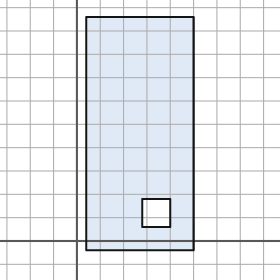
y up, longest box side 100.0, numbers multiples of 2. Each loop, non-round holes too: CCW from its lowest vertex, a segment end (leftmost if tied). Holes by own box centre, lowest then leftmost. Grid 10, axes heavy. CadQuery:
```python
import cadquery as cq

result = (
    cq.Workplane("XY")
    .moveTo(4.0, -4.0)
    .lineTo(50.0, -4.0)
    .lineTo(50.0, 96.0)
    .lineTo(4.0, 96.0)
    .close()
    .moveTo(28.0, 6.0)
    .lineTo(40.0, 6.0)
    .lineTo(40.0, 18.0)
    .lineTo(28.0, 18.0)
    .close()
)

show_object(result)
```